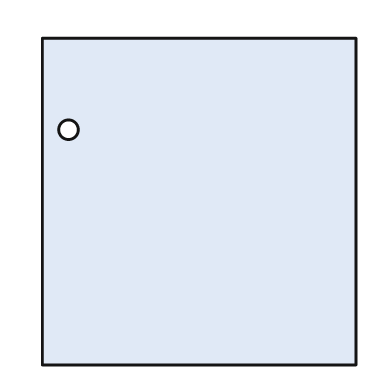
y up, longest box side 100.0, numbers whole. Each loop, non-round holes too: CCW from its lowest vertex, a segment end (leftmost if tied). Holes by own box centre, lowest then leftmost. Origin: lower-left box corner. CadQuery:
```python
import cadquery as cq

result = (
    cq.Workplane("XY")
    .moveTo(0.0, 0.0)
    .lineTo(96.0, 0.0)
    .lineTo(96.0, 100.0)
    .lineTo(0.0, 100.0)
    .close()
    .moveTo(8.0, 72.0)
    .circle(3.0)
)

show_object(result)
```